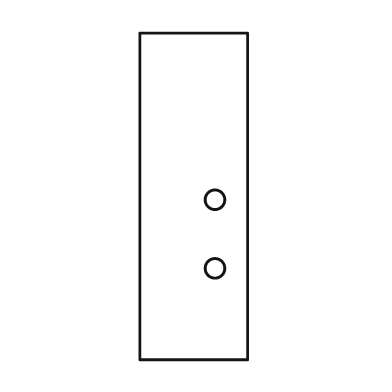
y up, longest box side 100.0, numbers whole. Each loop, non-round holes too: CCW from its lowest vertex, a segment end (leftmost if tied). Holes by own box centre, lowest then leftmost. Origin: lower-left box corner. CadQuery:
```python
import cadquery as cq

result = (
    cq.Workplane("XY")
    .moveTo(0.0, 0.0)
    .lineTo(33.0, 0.0)
    .lineTo(33.0, 100.0)
    .lineTo(0.0, 100.0)
    .close()
    .moveTo(23.0, 28.0)
    .circle(3.0)
    .moveTo(23.0, 49.0)
    .circle(3.0)
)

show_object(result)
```